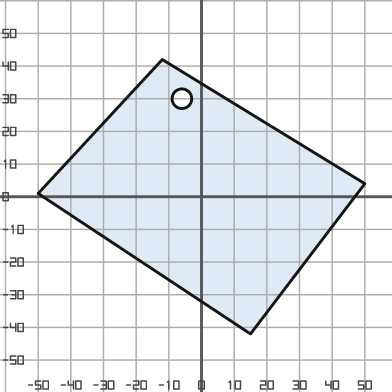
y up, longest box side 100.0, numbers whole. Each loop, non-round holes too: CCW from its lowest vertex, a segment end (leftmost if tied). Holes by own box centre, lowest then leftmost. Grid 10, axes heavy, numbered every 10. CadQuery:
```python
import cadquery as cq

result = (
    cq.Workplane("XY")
    .moveTo(15.0, -42.0)
    .lineTo(50.0, 4.0)
    .lineTo(-12.0, 42.0)
    .lineTo(-50.0, 1.0)
    .close()
    .moveTo(-6.0, 30.0)
    .circle(3.0)
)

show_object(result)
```